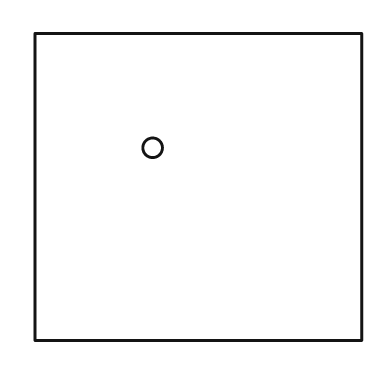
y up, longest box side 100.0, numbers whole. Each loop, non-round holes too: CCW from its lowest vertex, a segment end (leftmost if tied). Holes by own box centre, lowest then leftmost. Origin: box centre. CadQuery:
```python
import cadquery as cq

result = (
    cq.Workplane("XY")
    .moveTo(-50.0, -47.0)
    .lineTo(50.0, -47.0)
    .lineTo(50.0, 47.0)
    .lineTo(-50.0, 47.0)
    .close()
    .moveTo(-14.0, 12.0)
    .circle(3.0)
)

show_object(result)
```